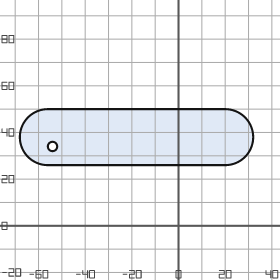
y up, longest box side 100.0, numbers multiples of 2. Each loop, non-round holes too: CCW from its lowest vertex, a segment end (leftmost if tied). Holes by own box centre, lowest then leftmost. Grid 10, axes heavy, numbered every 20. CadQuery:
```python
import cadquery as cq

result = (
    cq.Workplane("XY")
    .moveTo(-56.0, 26.0)
    .lineTo(20.0, 26.0)
    .threePointArc((32.0, 38.0), (20.0, 50.0))
    .lineTo(-56.0, 50.0)
    .threePointArc((-68.0, 38.0), (-56.0, 26.0))
    .close()
    .moveTo(-54.0, 34.0)
    .circle(2.0)
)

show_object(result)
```